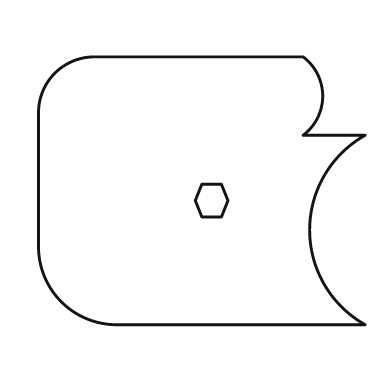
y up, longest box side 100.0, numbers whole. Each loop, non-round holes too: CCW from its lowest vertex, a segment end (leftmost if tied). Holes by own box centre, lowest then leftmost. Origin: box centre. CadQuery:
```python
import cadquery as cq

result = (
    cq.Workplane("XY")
    .moveTo(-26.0, -41.0)
    .lineTo(50.0, -41.0)
    .threePointArc((33.0, -12.0), (50.0, 17.0))
    .lineTo(31.0, 17.0)
    .threePointArc((37.0, 29.0), (31.0, 41.0))
    .lineTo(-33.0, 41.0)
    .threePointArc((-45.0, 36.0), (-50.0, 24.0))
    .lineTo(-50.0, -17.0)
    .threePointArc((-43.0, -34.0), (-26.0, -41.0))
    .close()
    .moveTo(0.0, -8.0)
    .lineTo(6.0, -8.0)
    .lineTo(8.0, -3.0)
    .lineTo(6.0, 2.0)
    .lineTo(0.0, 2.0)
    .lineTo(-2.0, -3.0)
    .close()
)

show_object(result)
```